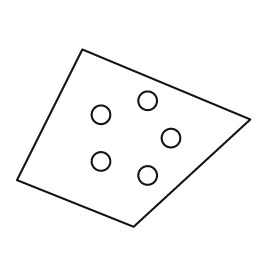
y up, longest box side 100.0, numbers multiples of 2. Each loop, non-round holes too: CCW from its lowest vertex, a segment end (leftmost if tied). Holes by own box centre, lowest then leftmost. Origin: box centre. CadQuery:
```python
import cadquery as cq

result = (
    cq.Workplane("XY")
    .moveTo(0.0, -38.0)
    .lineTo(50.0, 8.0)
    .lineTo(-22.0, 38.0)
    .lineTo(-50.0, -18.0)
    .close()
    .moveTo(6.0, -16.0)
    .circle(4.0)
    .moveTo(-14.0, -10.0)
    .circle(4.0)
    .moveTo(16.0, 0.0)
    .circle(4.0)
    .moveTo(-14.0, 10.0)
    .circle(4.0)
    .moveTo(6.0, 16.0)
    .circle(4.0)
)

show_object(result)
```